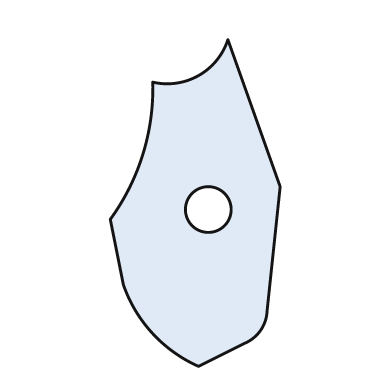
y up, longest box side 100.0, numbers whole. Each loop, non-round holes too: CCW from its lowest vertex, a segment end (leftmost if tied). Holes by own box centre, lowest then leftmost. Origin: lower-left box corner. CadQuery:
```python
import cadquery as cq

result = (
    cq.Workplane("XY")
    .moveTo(27.0, 0.0)
    .lineTo(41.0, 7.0)
    .threePointArc((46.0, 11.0), (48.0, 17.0))
    .lineTo(52.0, 55.0)
    .lineTo(36.0, 100.0)
    .threePointArc((27.0, 89.0), (13.0, 87.0))
    .threePointArc((10.0, 65.0), (0.0, 45.0))
    .lineTo(4.0, 25.0)
    .threePointArc((13.0, 10.0), (27.0, 0.0))
    .close()
    .moveTo(30.0, 48.0)
    .circle(7.0)
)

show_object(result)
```